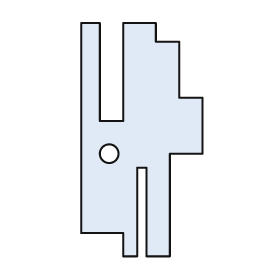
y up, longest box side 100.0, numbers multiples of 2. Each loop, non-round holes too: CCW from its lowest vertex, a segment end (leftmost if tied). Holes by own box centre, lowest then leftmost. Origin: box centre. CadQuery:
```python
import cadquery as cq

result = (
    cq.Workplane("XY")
    .moveTo(-8.0, -50.0)
    .lineTo(-2.0, -50.0)
    .lineTo(-2.0, -12.0)
    .lineTo(2.0, -12.0)
    .lineTo(2.0, -50.0)
    .lineTo(12.0, -50.0)
    .lineTo(12.0, -6.0)
    .lineTo(26.0, -6.0)
    .lineTo(26.0, 18.0)
    .lineTo(16.0, 18.0)
    .lineTo(16.0, 42.0)
    .lineTo(6.0, 42.0)
    .lineTo(6.0, 50.0)
    .lineTo(-8.0, 50.0)
    .lineTo(-8.0, 8.0)
    .lineTo(-18.0, 8.0)
    .lineTo(-18.0, 50.0)
    .lineTo(-26.0, 50.0)
    .lineTo(-26.0, -40.0)
    .lineTo(-8.0, -40.0)
    .close()
    .moveTo(-14.0, -6.0)
    .circle(4.0)
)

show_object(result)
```